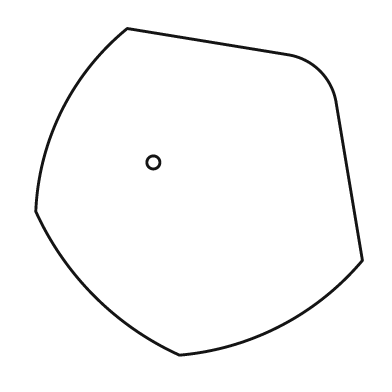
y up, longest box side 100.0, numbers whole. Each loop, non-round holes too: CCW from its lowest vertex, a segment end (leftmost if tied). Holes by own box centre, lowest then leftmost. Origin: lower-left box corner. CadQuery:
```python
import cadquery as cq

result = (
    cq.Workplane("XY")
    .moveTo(44.0, 0.0)
    .threePointArc((75.0, 9.0), (100.0, 29.0))
    .lineTo(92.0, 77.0)
    .threePointArc((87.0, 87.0), (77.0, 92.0))
    .lineTo(28.0, 100.0)
    .threePointArc((8.0, 75.0), (0.0, 44.0))
    .threePointArc((18.0, 18.0), (44.0, 0.0))
    .close()
    .moveTo(36.0, 59.0)
    .circle(2.0)
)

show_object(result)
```